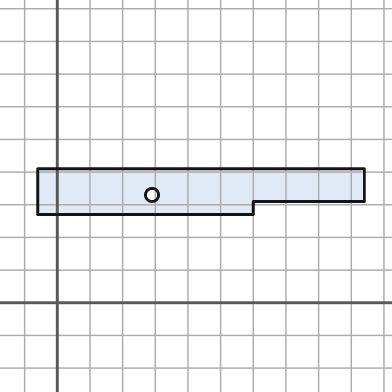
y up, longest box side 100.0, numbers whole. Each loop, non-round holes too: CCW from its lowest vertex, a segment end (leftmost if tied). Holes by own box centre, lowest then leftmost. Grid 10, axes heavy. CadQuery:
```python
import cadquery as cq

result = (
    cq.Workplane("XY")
    .moveTo(-6.0, 27.0)
    .lineTo(60.0, 27.0)
    .lineTo(60.0, 31.0)
    .lineTo(94.0, 31.0)
    .lineTo(94.0, 41.0)
    .lineTo(-6.0, 41.0)
    .close()
    .moveTo(29.0, 33.0)
    .circle(2.0)
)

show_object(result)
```